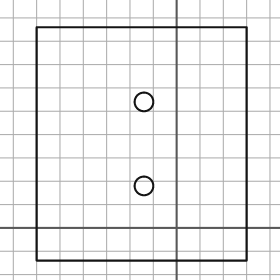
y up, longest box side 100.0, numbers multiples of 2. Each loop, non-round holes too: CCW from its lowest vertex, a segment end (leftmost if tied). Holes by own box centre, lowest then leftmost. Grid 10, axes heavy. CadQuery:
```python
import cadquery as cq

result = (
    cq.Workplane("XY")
    .moveTo(-60.0, -14.0)
    .lineTo(30.0, -14.0)
    .lineTo(30.0, 86.0)
    .lineTo(-60.0, 86.0)
    .close()
    .moveTo(-14.0, 18.0)
    .circle(4.0)
    .moveTo(-14.0, 54.0)
    .circle(4.0)
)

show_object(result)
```